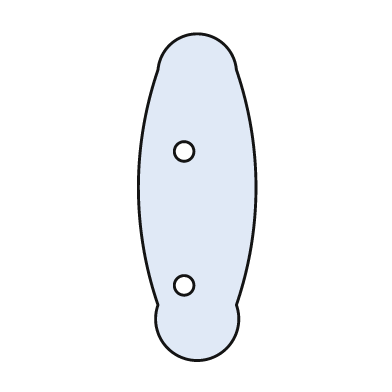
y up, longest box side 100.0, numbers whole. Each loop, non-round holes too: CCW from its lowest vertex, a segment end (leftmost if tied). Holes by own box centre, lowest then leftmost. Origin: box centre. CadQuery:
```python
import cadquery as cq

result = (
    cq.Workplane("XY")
    .moveTo(-12.0, -33.0)
    .threePointArc((0.0, -50.0), (12.0, -33.0))
    .threePointArc((18.0, 3.0), (12.0, 39.0))
    .threePointArc((0.0, 50.0), (-12.0, 39.0))
    .threePointArc((-18.0, 3.0), (-12.0, -33.0))
    .close()
    .moveTo(-4.0, -27.0)
    .circle(3.0)
    .moveTo(-4.0, 14.0)
    .circle(3.0)
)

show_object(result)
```